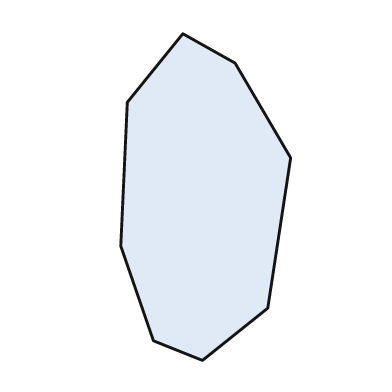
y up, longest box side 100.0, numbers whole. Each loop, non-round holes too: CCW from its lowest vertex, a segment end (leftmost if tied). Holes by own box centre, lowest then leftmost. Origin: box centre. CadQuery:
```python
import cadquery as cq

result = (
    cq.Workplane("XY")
    .moveTo(-1.0, -50.0)
    .lineTo(19.0, -34.0)
    .lineTo(26.0, 12.0)
    .lineTo(9.0, 41.0)
    .lineTo(-7.0, 50.0)
    .lineTo(-24.0, 29.0)
    .lineTo(-26.0, -15.0)
    .lineTo(-16.0, -44.0)
    .close()
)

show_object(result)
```